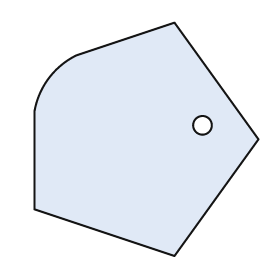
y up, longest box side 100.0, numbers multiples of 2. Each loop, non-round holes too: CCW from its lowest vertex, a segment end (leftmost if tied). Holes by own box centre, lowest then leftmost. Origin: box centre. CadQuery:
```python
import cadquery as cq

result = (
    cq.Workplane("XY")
    .moveTo(12.0, -50.0)
    .lineTo(48.0, 0.0)
    .lineTo(12.0, 50.0)
    .lineTo(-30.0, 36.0)
    .threePointArc((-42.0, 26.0), (-48.0, 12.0))
    .lineTo(-48.0, -30.0)
    .close()
    .moveTo(24.0, 6.0)
    .circle(4.0)
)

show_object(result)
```